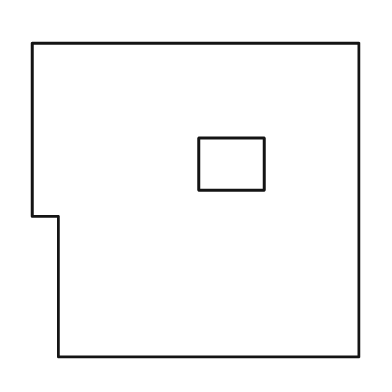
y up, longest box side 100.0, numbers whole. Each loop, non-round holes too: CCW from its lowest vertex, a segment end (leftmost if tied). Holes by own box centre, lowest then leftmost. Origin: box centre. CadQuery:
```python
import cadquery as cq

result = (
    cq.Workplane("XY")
    .moveTo(-42.0, -48.0)
    .lineTo(50.0, -48.0)
    .lineTo(50.0, 48.0)
    .lineTo(-50.0, 48.0)
    .lineTo(-50.0, -5.0)
    .lineTo(-42.0, -5.0)
    .close()
    .moveTo(1.0, 3.0)
    .lineTo(21.0, 3.0)
    .lineTo(21.0, 19.0)
    .lineTo(1.0, 19.0)
    .close()
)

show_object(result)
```